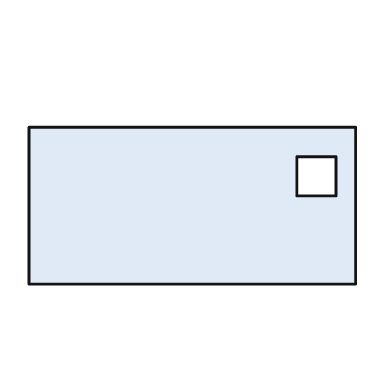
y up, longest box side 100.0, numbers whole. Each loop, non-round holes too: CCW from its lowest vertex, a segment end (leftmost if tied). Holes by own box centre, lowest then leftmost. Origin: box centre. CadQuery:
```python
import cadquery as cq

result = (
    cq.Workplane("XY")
    .moveTo(-50.0, -24.0)
    .lineTo(50.0, -24.0)
    .lineTo(50.0, 24.0)
    .lineTo(-50.0, 24.0)
    .close()
    .moveTo(32.0, 3.0)
    .lineTo(44.0, 3.0)
    .lineTo(44.0, 15.0)
    .lineTo(32.0, 15.0)
    .close()
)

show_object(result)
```